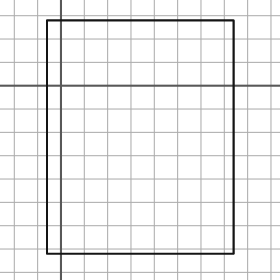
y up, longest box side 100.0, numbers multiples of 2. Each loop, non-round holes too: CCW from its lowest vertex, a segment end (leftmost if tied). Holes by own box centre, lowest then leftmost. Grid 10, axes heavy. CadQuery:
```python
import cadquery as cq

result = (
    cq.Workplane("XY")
    .moveTo(-6.0, -72.0)
    .lineTo(74.0, -72.0)
    .lineTo(74.0, 28.0)
    .lineTo(-6.0, 28.0)
    .close()
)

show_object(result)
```